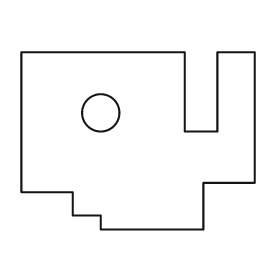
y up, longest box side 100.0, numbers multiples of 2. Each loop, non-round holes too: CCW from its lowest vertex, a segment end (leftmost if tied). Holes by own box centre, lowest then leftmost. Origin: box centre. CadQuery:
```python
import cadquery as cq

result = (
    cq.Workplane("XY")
    .moveTo(-16.0, -38.0)
    .lineTo(28.0, -38.0)
    .lineTo(28.0, -18.0)
    .lineTo(50.0, -18.0)
    .lineTo(50.0, 38.0)
    .lineTo(34.0, 38.0)
    .lineTo(34.0, 4.0)
    .lineTo(20.0, 4.0)
    .lineTo(20.0, 38.0)
    .lineTo(-50.0, 38.0)
    .lineTo(-50.0, -22.0)
    .lineTo(-28.0, -22.0)
    .lineTo(-28.0, -32.0)
    .lineTo(-16.0, -32.0)
    .close()
    .moveTo(-16.0, 12.0)
    .circle(8.0)
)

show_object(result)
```